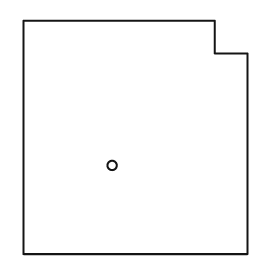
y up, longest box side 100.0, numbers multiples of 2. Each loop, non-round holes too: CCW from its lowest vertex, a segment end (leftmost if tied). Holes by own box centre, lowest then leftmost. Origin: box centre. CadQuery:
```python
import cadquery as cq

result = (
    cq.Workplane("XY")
    .moveTo(-48.0, -50.0)
    .lineTo(48.0, -50.0)
    .lineTo(48.0, 36.0)
    .lineTo(34.0, 36.0)
    .lineTo(34.0, 50.0)
    .lineTo(-48.0, 50.0)
    .close()
    .moveTo(-10.0, -12.0)
    .circle(2.0)
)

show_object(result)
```